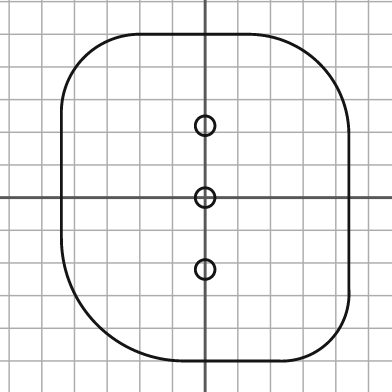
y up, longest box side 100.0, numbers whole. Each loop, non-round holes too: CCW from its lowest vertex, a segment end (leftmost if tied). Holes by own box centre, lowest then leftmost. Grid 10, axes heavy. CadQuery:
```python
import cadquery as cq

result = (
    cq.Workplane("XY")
    .moveTo(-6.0, -50.0)
    .lineTo(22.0, -50.0)
    .threePointArc((38.0, -44.0), (44.0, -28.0))
    .lineTo(44.0, 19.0)
    .threePointArc((35.0, 41.0), (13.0, 50.0))
    .lineTo(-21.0, 50.0)
    .threePointArc((-37.0, 43.0), (-44.0, 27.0))
    .lineTo(-44.0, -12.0)
    .threePointArc((-33.0, -39.0), (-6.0, -50.0))
    .close()
    .moveTo(0.0, -22.0)
    .circle(3.0)
    .moveTo(0.0, 0.0)
    .circle(3.0)
    .moveTo(0.0, 22.0)
    .circle(3.0)
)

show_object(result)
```